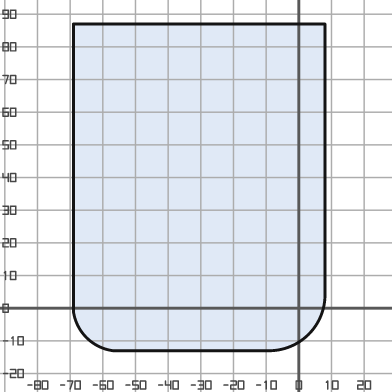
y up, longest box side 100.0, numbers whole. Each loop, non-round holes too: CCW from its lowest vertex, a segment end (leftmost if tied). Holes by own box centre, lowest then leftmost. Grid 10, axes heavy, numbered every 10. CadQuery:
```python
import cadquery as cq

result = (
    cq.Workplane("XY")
    .moveTo(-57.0, -13.0)
    .lineTo(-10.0, -13.0)
    .threePointArc((3.0, -8.0), (8.0, 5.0))
    .lineTo(8.0, 87.0)
    .lineTo(-69.0, 87.0)
    .lineTo(-69.0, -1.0)
    .threePointArc((-65.0, -9.0), (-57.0, -13.0))
    .close()
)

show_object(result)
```